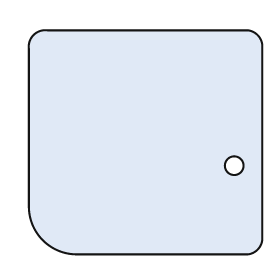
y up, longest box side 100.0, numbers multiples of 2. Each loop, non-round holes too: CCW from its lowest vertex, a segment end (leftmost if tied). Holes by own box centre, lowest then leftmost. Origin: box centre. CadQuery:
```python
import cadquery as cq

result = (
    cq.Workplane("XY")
    .moveTo(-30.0, -48.0)
    .lineTo(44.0, -48.0)
    .threePointArc((48.0, -46.0), (50.0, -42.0))
    .lineTo(50.0, 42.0)
    .threePointArc((48.0, 46.0), (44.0, 48.0))
    .lineTo(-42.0, 48.0)
    .threePointArc((-48.0, 46.0), (-50.0, 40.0))
    .lineTo(-50.0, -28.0)
    .threePointArc((-44.0, -42.0), (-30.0, -48.0))
    .close()
    .moveTo(38.0, -10.0)
    .circle(4.0)
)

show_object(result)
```